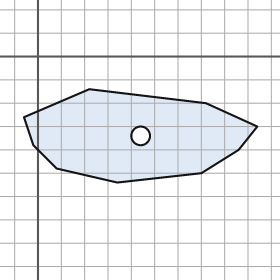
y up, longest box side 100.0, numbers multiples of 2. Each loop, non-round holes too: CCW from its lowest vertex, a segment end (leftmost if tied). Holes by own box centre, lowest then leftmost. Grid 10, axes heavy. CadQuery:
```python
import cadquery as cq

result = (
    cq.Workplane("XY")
    .moveTo(34.0, -54.0)
    .lineTo(70.0, -50.0)
    .lineTo(86.0, -40.0)
    .lineTo(94.0, -30.0)
    .lineTo(72.0, -20.0)
    .lineTo(22.0, -14.0)
    .lineTo(-6.0, -26.0)
    .lineTo(-2.0, -38.0)
    .lineTo(8.0, -48.0)
    .close()
    .moveTo(44.0, -34.0)
    .circle(4.0)
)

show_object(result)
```